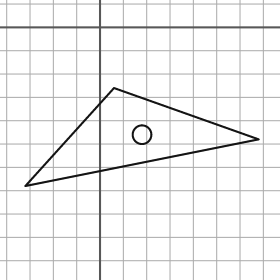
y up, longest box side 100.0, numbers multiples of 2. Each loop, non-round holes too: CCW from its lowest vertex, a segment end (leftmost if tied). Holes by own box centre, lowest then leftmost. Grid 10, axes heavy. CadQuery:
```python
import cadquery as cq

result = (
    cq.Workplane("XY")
    .moveTo(-32.0, -68.0)
    .lineTo(68.0, -48.0)
    .lineTo(6.0, -26.0)
    .close()
    .moveTo(18.0, -46.0)
    .circle(4.0)
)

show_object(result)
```